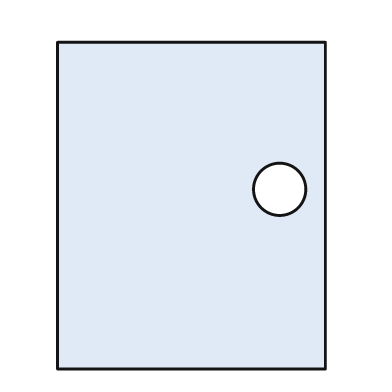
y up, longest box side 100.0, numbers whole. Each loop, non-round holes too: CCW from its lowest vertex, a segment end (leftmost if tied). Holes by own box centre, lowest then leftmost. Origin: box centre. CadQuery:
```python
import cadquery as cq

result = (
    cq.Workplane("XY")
    .moveTo(-41.0, -50.0)
    .lineTo(41.0, -50.0)
    .lineTo(41.0, 50.0)
    .lineTo(-41.0, 50.0)
    .close()
    .moveTo(27.0, 5.0)
    .circle(8.0)
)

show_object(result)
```